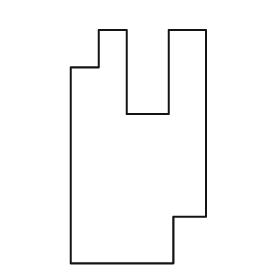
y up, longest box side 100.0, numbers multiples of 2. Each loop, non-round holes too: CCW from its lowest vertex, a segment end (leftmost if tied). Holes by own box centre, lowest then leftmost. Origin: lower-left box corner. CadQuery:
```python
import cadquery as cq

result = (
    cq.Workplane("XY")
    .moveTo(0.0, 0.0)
    .lineTo(44.0, 0.0)
    .lineTo(44.0, 20.0)
    .lineTo(58.0, 20.0)
    .lineTo(58.0, 100.0)
    .lineTo(42.0, 100.0)
    .lineTo(42.0, 64.0)
    .lineTo(24.0, 64.0)
    .lineTo(24.0, 100.0)
    .lineTo(12.0, 100.0)
    .lineTo(12.0, 84.0)
    .lineTo(0.0, 84.0)
    .close()
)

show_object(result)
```